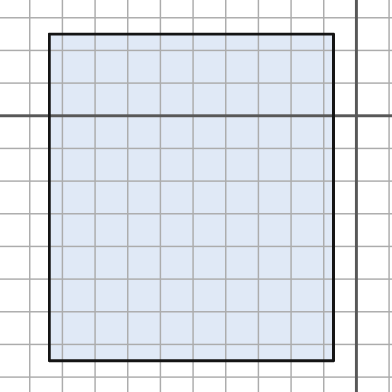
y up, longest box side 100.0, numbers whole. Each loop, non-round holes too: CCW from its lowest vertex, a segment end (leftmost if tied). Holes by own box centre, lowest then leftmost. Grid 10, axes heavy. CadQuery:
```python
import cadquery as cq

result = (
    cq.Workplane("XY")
    .moveTo(-94.0, -75.0)
    .lineTo(-7.0, -75.0)
    .lineTo(-7.0, 25.0)
    .lineTo(-94.0, 25.0)
    .close()
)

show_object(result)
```